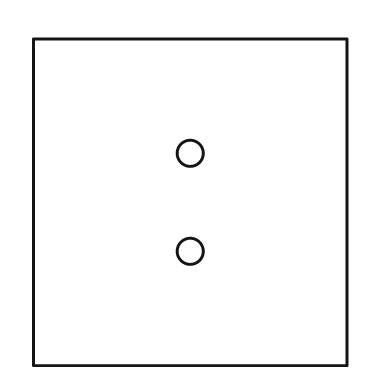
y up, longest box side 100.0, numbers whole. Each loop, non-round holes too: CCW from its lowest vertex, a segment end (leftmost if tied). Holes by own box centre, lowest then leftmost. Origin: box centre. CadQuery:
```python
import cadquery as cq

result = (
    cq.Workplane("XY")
    .moveTo(-48.0, -50.0)
    .lineTo(48.0, -50.0)
    .lineTo(48.0, 50.0)
    .lineTo(-48.0, 50.0)
    .close()
    .moveTo(0.0, -15.0)
    .circle(4.0)
    .moveTo(0.0, 15.0)
    .circle(4.0)
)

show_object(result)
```